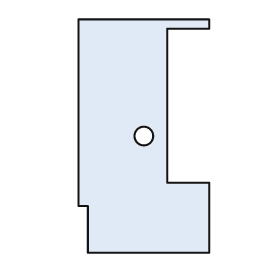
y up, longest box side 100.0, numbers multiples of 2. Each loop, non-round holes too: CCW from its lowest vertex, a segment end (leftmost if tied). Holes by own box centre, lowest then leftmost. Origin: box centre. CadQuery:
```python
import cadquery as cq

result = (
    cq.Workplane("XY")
    .moveTo(-24.0, -50.0)
    .lineTo(28.0, -50.0)
    .lineTo(28.0, -20.0)
    .lineTo(10.0, -20.0)
    .lineTo(10.0, 46.0)
    .lineTo(28.0, 46.0)
    .lineTo(28.0, 50.0)
    .lineTo(-28.0, 50.0)
    .lineTo(-28.0, -30.0)
    .lineTo(-24.0, -30.0)
    .close()
    .moveTo(0.0, 0.0)
    .circle(4.0)
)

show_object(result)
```